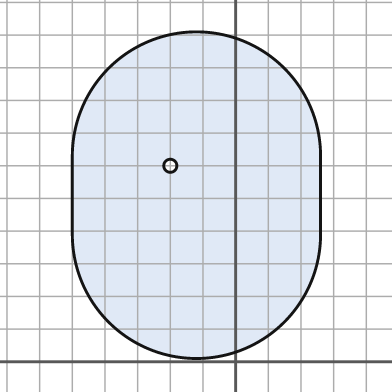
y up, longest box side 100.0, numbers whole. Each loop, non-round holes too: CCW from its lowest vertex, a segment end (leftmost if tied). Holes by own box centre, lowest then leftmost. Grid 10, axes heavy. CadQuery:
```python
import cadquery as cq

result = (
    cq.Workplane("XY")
    .moveTo(-50.0, 39.0)
    .threePointArc((-12.0, 1.0), (26.0, 39.0))
    .lineTo(26.0, 63.0)
    .threePointArc((-12.0, 101.0), (-50.0, 63.0))
    .close()
    .moveTo(-20.0, 60.0)
    .circle(2.0)
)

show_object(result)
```